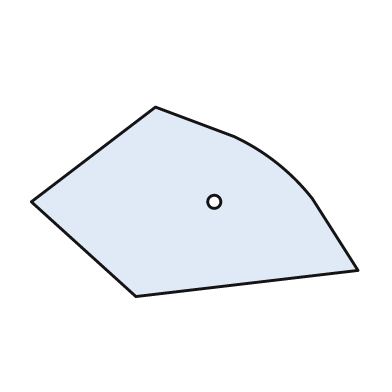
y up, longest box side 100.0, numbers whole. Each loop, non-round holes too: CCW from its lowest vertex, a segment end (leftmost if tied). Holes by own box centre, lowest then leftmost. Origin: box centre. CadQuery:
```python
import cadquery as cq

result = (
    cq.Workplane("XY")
    .moveTo(-18.0, -29.0)
    .lineTo(50.0, -21.0)
    .lineTo(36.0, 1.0)
    .threePointArc((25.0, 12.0), (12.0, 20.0))
    .lineTo(-12.0, 29.0)
    .lineTo(-50.0, 0.0)
    .close()
    .moveTo(6.0, 0.0)
    .circle(2.0)
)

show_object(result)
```